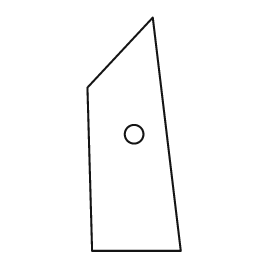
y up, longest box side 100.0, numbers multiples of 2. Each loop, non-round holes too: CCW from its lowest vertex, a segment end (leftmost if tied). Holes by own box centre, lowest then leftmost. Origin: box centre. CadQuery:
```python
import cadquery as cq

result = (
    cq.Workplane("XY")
    .moveTo(-18.0, -50.0)
    .lineTo(20.0, -50.0)
    .lineTo(8.0, 50.0)
    .lineTo(-20.0, 20.0)
    .close()
    .moveTo(0.0, 0.0)
    .circle(4.0)
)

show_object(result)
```